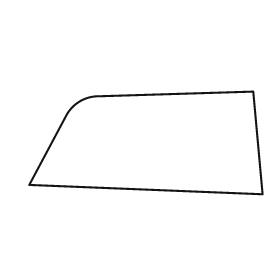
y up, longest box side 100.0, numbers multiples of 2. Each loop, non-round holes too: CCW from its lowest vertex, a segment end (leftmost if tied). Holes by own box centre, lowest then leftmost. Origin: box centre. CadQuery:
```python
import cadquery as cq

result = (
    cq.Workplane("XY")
    .moveTo(50.0, -22.0)
    .lineTo(46.0, 22.0)
    .lineTo(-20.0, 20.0)
    .threePointArc((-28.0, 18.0), (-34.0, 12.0))
    .lineTo(-50.0, -18.0)
    .close()
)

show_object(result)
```